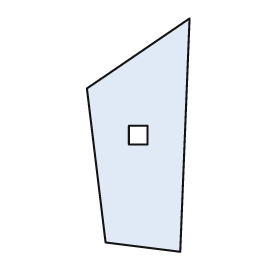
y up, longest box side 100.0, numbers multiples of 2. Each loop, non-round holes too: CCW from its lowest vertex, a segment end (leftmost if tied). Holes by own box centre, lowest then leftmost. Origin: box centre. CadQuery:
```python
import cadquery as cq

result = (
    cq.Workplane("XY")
    .moveTo(18.0, -50.0)
    .lineTo(22.0, 50.0)
    .lineTo(-22.0, 20.0)
    .lineTo(-14.0, -46.0)
    .close()
    .moveTo(-4.0, -4.0)
    .lineTo(4.0, -4.0)
    .lineTo(4.0, 4.0)
    .lineTo(-4.0, 4.0)
    .close()
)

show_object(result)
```